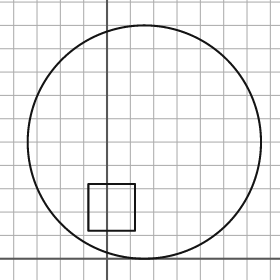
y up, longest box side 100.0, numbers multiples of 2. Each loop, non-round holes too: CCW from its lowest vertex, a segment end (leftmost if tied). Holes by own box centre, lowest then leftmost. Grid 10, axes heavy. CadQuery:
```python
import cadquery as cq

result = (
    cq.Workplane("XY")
    .moveTo(16.0, 50.0)
    .circle(50.0)
    .moveTo(-8.0, 12.0)
    .lineTo(12.0, 12.0)
    .lineTo(12.0, 32.0)
    .lineTo(-8.0, 32.0)
    .close()
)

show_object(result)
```